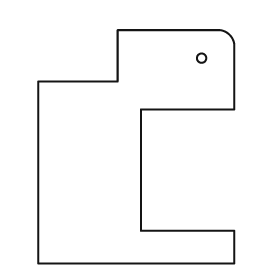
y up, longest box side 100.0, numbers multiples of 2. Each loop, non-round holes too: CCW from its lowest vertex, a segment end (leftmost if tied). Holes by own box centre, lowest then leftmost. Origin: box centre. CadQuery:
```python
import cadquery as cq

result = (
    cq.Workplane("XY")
    .moveTo(-42.0, -50.0)
    .lineTo(42.0, -50.0)
    .lineTo(42.0, -36.0)
    .lineTo(2.0, -36.0)
    .lineTo(2.0, 16.0)
    .lineTo(42.0, 16.0)
    .lineTo(42.0, 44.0)
    .threePointArc((40.0, 48.0), (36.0, 50.0))
    .lineTo(-8.0, 50.0)
    .lineTo(-8.0, 28.0)
    .lineTo(-42.0, 28.0)
    .close()
    .moveTo(28.0, 38.0)
    .circle(2.0)
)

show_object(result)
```